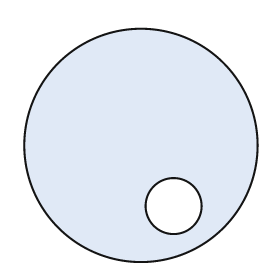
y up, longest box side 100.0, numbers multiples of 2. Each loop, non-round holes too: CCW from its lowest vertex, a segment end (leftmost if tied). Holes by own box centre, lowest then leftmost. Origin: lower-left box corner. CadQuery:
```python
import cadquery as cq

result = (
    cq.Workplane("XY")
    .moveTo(50.0, 50.0)
    .circle(50.0)
    .moveTo(64.0, 24.0)
    .circle(12.0)
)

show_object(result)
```